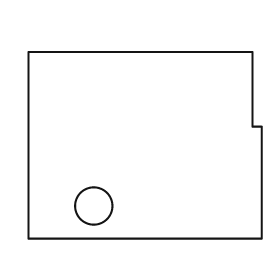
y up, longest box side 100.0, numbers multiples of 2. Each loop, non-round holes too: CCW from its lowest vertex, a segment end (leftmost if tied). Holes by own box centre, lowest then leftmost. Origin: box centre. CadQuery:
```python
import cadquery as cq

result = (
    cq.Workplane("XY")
    .moveTo(-50.0, -40.0)
    .lineTo(50.0, -40.0)
    .lineTo(50.0, 8.0)
    .lineTo(46.0, 8.0)
    .lineTo(46.0, 40.0)
    .lineTo(-50.0, 40.0)
    .close()
    .moveTo(-22.0, -26.0)
    .circle(8.0)
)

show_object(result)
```